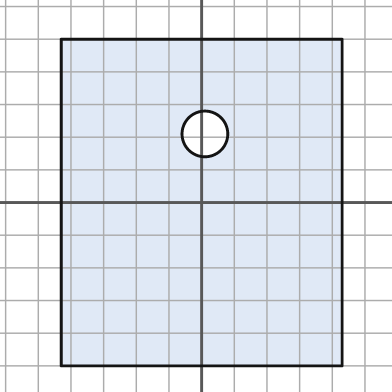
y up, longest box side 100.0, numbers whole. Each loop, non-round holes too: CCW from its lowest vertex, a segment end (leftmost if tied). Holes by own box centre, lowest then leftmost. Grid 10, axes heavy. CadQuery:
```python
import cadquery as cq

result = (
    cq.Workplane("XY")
    .moveTo(-43.0, -50.0)
    .lineTo(43.0, -50.0)
    .lineTo(43.0, 50.0)
    .lineTo(-43.0, 50.0)
    .close()
    .moveTo(1.0, 21.0)
    .circle(7.0)
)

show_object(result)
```